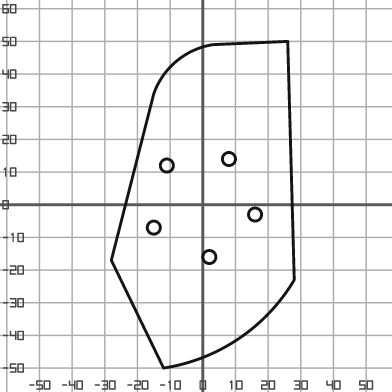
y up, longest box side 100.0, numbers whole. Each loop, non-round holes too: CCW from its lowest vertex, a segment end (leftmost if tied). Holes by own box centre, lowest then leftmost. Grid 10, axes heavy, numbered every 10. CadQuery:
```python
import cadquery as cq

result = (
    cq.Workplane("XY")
    .moveTo(-12.0, -50.0)
    .threePointArc((11.0, -41.0), (28.0, -23.0))
    .lineTo(26.0, 50.0)
    .lineTo(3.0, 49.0)
    .threePointArc((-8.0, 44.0), (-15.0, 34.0))
    .lineTo(-28.0, -17.0)
    .close()
    .moveTo(2.0, -16.0)
    .circle(2.0)
    .moveTo(-15.0, -7.0)
    .circle(2.0)
    .moveTo(16.0, -3.0)
    .circle(2.0)
    .moveTo(-11.0, 12.0)
    .circle(2.0)
    .moveTo(8.0, 14.0)
    .circle(2.0)
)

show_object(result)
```